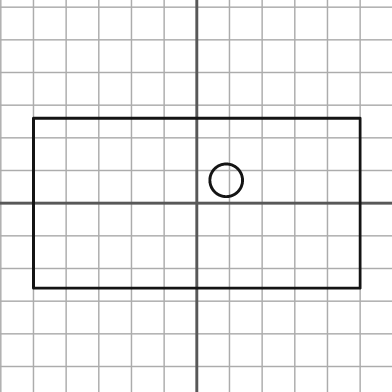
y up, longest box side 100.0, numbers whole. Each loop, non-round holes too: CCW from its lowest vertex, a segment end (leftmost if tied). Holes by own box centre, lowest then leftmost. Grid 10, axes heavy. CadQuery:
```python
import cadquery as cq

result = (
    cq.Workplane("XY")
    .moveTo(-50.0, -26.0)
    .lineTo(50.0, -26.0)
    .lineTo(50.0, 26.0)
    .lineTo(-50.0, 26.0)
    .close()
    .moveTo(9.0, 7.0)
    .circle(5.0)
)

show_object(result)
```